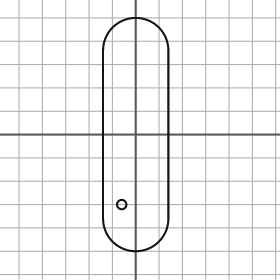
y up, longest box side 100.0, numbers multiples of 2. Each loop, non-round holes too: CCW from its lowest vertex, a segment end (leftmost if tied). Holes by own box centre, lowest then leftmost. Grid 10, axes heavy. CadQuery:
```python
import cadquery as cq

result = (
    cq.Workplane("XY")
    .moveTo(-14.0, -36.0)
    .threePointArc((0.0, -50.0), (14.0, -36.0))
    .lineTo(14.0, 36.0)
    .threePointArc((0.0, 50.0), (-14.0, 36.0))
    .close()
    .moveTo(-6.0, -30.0)
    .circle(2.0)
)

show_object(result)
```